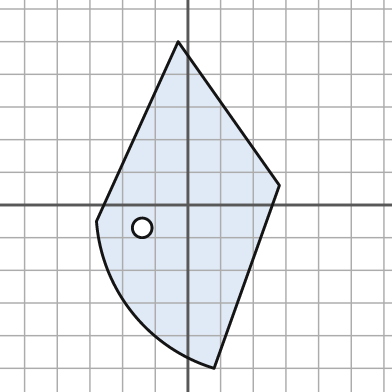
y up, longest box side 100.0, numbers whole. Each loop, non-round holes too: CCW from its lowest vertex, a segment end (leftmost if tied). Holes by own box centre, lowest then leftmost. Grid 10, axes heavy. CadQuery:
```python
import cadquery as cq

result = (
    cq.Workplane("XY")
    .moveTo(8.0, -50.0)
    .lineTo(28.0, 6.0)
    .lineTo(-3.0, 50.0)
    .lineTo(-28.0, -5.0)
    .threePointArc((-17.0, -33.0), (8.0, -50.0))
    .close()
    .moveTo(-14.0, -7.0)
    .circle(3.0)
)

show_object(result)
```